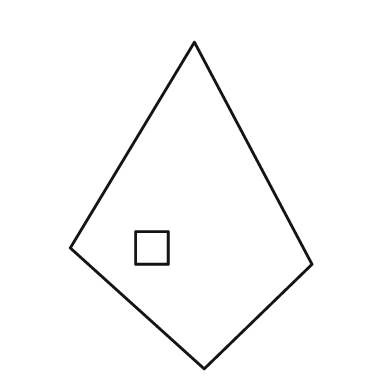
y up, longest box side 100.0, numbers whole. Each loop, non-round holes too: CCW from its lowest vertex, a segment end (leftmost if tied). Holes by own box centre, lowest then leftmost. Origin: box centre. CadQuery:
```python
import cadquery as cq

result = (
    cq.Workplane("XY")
    .moveTo(4.0, -50.0)
    .lineTo(37.0, -18.0)
    .lineTo(1.0, 50.0)
    .lineTo(-37.0, -13.0)
    .close()
    .moveTo(-17.0, -18.0)
    .lineTo(-7.0, -18.0)
    .lineTo(-7.0, -8.0)
    .lineTo(-17.0, -8.0)
    .close()
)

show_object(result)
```